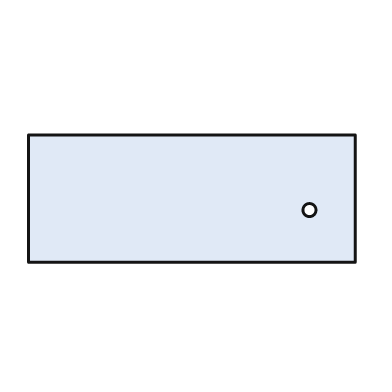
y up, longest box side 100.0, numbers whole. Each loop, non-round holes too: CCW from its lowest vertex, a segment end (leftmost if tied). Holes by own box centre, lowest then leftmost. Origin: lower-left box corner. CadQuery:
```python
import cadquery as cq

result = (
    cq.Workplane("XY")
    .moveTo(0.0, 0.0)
    .lineTo(100.0, 0.0)
    .lineTo(100.0, 39.0)
    .lineTo(0.0, 39.0)
    .close()
    .moveTo(86.0, 16.0)
    .circle(2.0)
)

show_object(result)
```